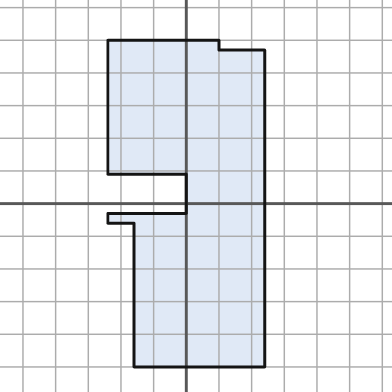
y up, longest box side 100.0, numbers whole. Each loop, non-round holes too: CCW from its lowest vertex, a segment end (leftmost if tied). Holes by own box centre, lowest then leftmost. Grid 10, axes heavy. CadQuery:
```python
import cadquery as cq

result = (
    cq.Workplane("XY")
    .moveTo(-16.0, -50.0)
    .lineTo(24.0, -50.0)
    .lineTo(24.0, 47.0)
    .lineTo(10.0, 47.0)
    .lineTo(10.0, 50.0)
    .lineTo(-24.0, 50.0)
    .lineTo(-24.0, 9.0)
    .lineTo(0.0, 9.0)
    .lineTo(0.0, -3.0)
    .lineTo(-24.0, -3.0)
    .lineTo(-24.0, -6.0)
    .lineTo(-16.0, -6.0)
    .close()
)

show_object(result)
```